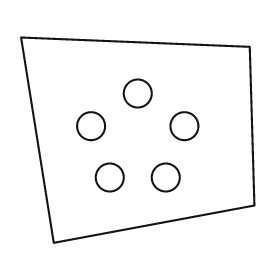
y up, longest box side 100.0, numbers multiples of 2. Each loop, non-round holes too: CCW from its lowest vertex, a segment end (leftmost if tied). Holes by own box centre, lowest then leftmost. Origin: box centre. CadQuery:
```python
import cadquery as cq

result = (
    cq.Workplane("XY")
    .moveTo(-36.0, -44.0)
    .lineTo(50.0, -28.0)
    .lineTo(48.0, 40.0)
    .lineTo(-50.0, 44.0)
    .close()
    .moveTo(-12.0, -16.0)
    .circle(6.0)
    .moveTo(12.0, -16.0)
    .circle(6.0)
    .moveTo(-20.0, 6.0)
    .circle(6.0)
    .moveTo(20.0, 6.0)
    .circle(6.0)
    .moveTo(0.0, 20.0)
    .circle(6.0)
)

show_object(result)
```